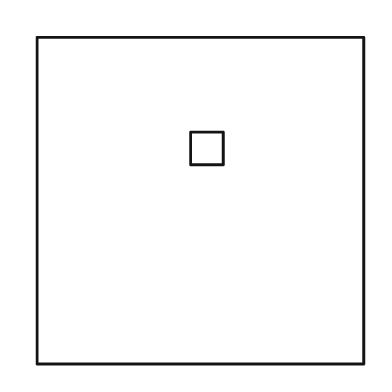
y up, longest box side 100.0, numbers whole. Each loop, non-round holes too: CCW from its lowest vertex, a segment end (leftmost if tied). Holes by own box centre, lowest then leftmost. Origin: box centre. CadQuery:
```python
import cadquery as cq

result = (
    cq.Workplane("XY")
    .moveTo(-50.0, -50.0)
    .lineTo(50.0, -50.0)
    .lineTo(50.0, 50.0)
    .lineTo(-50.0, 50.0)
    .close()
    .moveTo(-3.0, 11.0)
    .lineTo(7.0, 11.0)
    .lineTo(7.0, 21.0)
    .lineTo(-3.0, 21.0)
    .close()
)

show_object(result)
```